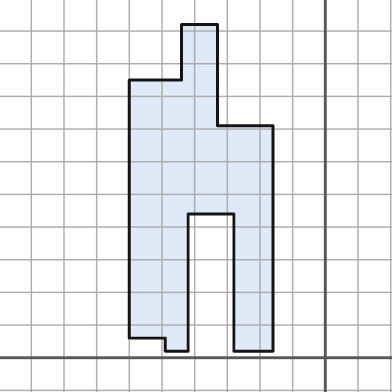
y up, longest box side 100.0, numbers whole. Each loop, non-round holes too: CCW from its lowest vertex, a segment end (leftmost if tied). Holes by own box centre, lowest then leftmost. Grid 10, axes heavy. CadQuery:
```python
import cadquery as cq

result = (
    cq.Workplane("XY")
    .moveTo(-49.0, 2.0)
    .lineTo(-42.0, 2.0)
    .lineTo(-42.0, 44.0)
    .lineTo(-28.0, 44.0)
    .lineTo(-28.0, 2.0)
    .lineTo(-16.0, 2.0)
    .lineTo(-16.0, 71.0)
    .lineTo(-33.0, 71.0)
    .lineTo(-33.0, 102.0)
    .lineTo(-44.0, 102.0)
    .lineTo(-44.0, 85.0)
    .lineTo(-60.0, 85.0)
    .lineTo(-60.0, 6.0)
    .lineTo(-49.0, 6.0)
    .close()
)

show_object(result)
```